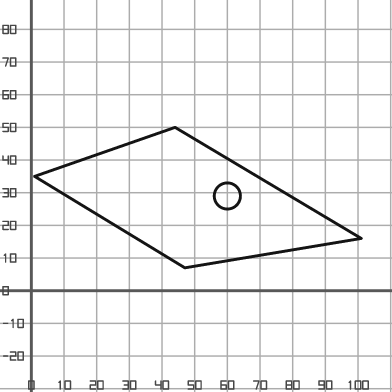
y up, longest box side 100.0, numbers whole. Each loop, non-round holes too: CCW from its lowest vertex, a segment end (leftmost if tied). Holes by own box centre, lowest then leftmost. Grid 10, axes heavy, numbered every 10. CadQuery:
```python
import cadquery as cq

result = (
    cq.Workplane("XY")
    .moveTo(47.0, 7.0)
    .lineTo(101.0, 16.0)
    .lineTo(44.0, 50.0)
    .lineTo(1.0, 35.0)
    .close()
    .moveTo(60.0, 29.0)
    .circle(4.0)
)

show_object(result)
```